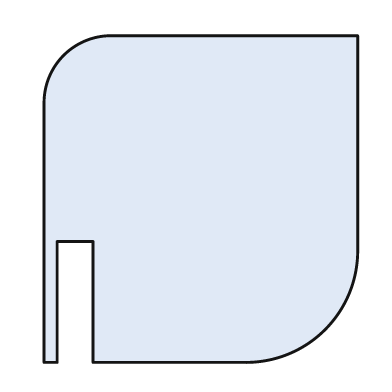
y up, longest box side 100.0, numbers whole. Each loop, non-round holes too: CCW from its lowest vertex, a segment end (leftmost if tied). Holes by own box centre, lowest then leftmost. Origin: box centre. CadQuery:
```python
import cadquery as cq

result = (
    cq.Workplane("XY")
    .moveTo(-48.0, -50.0)
    .lineTo(-44.0, -50.0)
    .lineTo(-44.0, -13.0)
    .lineTo(-33.0, -13.0)
    .lineTo(-33.0, -50.0)
    .lineTo(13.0, -50.0)
    .threePointArc((38.0, -40.0), (48.0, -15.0))
    .lineTo(48.0, 50.0)
    .lineTo(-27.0, 50.0)
    .threePointArc((-42.0, 44.0), (-48.0, 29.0))
    .close()
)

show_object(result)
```